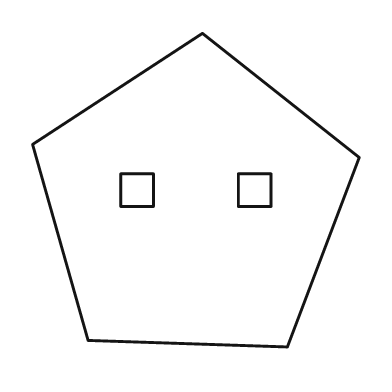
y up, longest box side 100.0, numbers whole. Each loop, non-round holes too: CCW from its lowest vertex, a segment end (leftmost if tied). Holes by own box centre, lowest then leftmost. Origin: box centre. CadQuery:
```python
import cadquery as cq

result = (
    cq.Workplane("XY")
    .moveTo(28.0, -48.0)
    .lineTo(50.0, 10.0)
    .lineTo(2.0, 48.0)
    .lineTo(-50.0, 14.0)
    .lineTo(-33.0, -46.0)
    .close()
    .moveTo(-23.0, -5.0)
    .lineTo(-13.0, -5.0)
    .lineTo(-13.0, 5.0)
    .lineTo(-23.0, 5.0)
    .close()
    .moveTo(13.0, -5.0)
    .lineTo(23.0, -5.0)
    .lineTo(23.0, 5.0)
    .lineTo(13.0, 5.0)
    .close()
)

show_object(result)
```